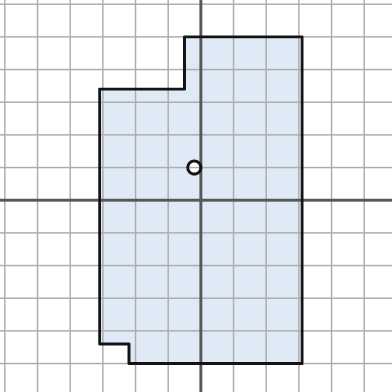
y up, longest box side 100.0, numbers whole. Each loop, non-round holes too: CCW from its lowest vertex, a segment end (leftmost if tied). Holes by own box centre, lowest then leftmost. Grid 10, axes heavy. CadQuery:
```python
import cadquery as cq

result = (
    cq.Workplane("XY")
    .moveTo(-22.0, -50.0)
    .lineTo(31.0, -50.0)
    .lineTo(31.0, 50.0)
    .lineTo(-5.0, 50.0)
    .lineTo(-5.0, 34.0)
    .lineTo(-31.0, 34.0)
    .lineTo(-31.0, -44.0)
    .lineTo(-22.0, -44.0)
    .close()
    .moveTo(-2.0, 10.0)
    .circle(2.0)
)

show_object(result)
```